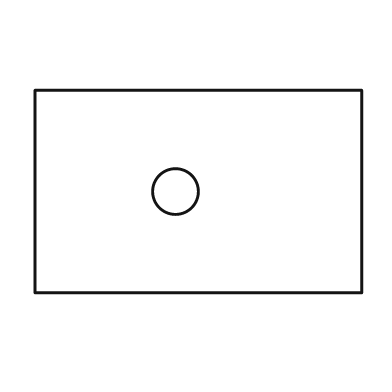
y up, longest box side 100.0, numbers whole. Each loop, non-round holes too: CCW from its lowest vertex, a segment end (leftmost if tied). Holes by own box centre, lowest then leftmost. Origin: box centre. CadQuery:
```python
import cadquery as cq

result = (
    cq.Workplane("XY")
    .moveTo(-50.0, -31.0)
    .lineTo(50.0, -31.0)
    .lineTo(50.0, 31.0)
    .lineTo(-50.0, 31.0)
    .close()
    .moveTo(-7.0, 0.0)
    .circle(7.0)
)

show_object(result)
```